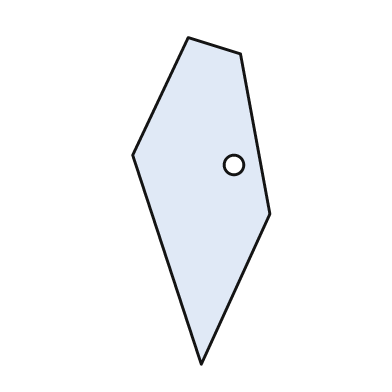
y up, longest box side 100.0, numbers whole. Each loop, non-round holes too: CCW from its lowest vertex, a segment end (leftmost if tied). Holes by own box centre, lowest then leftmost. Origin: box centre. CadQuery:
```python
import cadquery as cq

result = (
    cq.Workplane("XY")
    .moveTo(0.0, -50.0)
    .lineTo(21.0, -4.0)
    .lineTo(12.0, 45.0)
    .lineTo(-4.0, 50.0)
    .lineTo(-21.0, 14.0)
    .close()
    .moveTo(10.0, 11.0)
    .circle(3.0)
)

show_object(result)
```